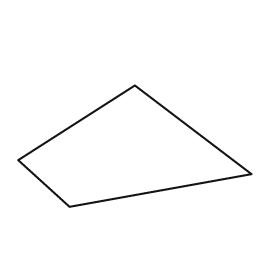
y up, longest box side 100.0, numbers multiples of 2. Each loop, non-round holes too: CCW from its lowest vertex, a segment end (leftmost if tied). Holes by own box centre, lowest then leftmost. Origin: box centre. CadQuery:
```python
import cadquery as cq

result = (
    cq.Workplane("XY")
    .moveTo(-28.0, -26.0)
    .lineTo(50.0, -12.0)
    .lineTo(0.0, 26.0)
    .lineTo(-50.0, -6.0)
    .close()
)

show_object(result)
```